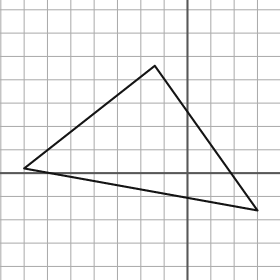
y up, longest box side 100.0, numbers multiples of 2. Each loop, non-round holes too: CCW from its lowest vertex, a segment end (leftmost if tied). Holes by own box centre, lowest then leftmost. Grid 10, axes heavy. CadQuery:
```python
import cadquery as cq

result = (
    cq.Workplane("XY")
    .moveTo(30.0, -16.0)
    .lineTo(-14.0, 46.0)
    .lineTo(-70.0, 2.0)
    .close()
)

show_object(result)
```